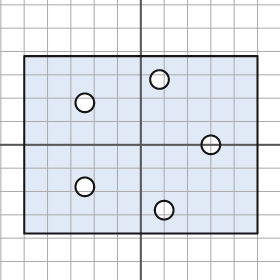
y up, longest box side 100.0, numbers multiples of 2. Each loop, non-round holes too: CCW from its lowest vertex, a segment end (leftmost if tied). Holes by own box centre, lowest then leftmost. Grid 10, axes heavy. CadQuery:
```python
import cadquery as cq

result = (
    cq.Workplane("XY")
    .moveTo(-50.0, -38.0)
    .lineTo(50.0, -38.0)
    .lineTo(50.0, 38.0)
    .lineTo(-50.0, 38.0)
    .close()
    .moveTo(10.0, -28.0)
    .circle(4.0)
    .moveTo(-24.0, -18.0)
    .circle(4.0)
    .moveTo(30.0, 0.0)
    .circle(4.0)
    .moveTo(-24.0, 18.0)
    .circle(4.0)
    .moveTo(8.0, 28.0)
    .circle(4.0)
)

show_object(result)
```